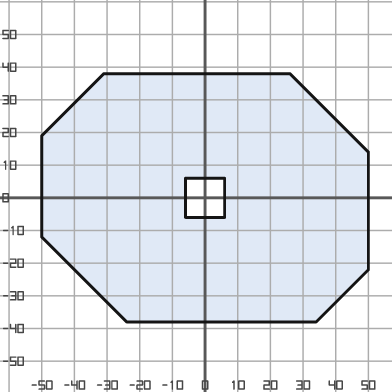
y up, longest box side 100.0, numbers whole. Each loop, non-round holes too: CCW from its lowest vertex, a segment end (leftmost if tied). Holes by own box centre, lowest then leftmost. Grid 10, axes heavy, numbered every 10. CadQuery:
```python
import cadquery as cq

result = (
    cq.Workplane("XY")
    .moveTo(-24.0, -38.0)
    .lineTo(34.0, -38.0)
    .lineTo(50.0, -22.0)
    .lineTo(50.0, 14.0)
    .lineTo(26.0, 38.0)
    .lineTo(-31.0, 38.0)
    .lineTo(-50.0, 19.0)
    .lineTo(-50.0, -12.0)
    .close()
    .moveTo(-6.0, -6.0)
    .lineTo(6.0, -6.0)
    .lineTo(6.0, 6.0)
    .lineTo(-6.0, 6.0)
    .close()
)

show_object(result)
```